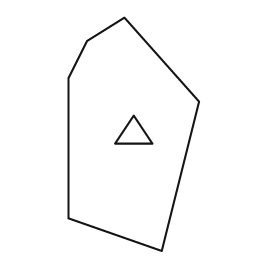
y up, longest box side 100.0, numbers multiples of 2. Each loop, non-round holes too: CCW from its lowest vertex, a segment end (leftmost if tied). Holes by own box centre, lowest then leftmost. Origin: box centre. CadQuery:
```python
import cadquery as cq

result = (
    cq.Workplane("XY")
    .moveTo(12.0, -50.0)
    .lineTo(28.0, 14.0)
    .lineTo(-4.0, 50.0)
    .lineTo(-20.0, 40.0)
    .lineTo(-28.0, 24.0)
    .lineTo(-28.0, -36.0)
    .close()
    .moveTo(-8.0, -4.0)
    .lineTo(8.0, -4.0)
    .lineTo(0.0, 8.0)
    .close()
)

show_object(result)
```